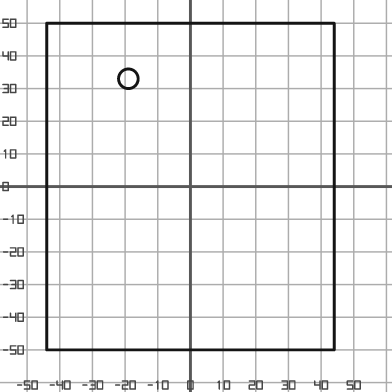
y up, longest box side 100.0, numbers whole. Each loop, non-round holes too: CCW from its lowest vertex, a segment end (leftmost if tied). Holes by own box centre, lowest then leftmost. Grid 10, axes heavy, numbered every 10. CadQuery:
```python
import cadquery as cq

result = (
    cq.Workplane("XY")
    .moveTo(-44.0, -50.0)
    .lineTo(44.0, -50.0)
    .lineTo(44.0, 50.0)
    .lineTo(-44.0, 50.0)
    .close()
    .moveTo(-19.0, 33.0)
    .circle(3.0)
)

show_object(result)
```